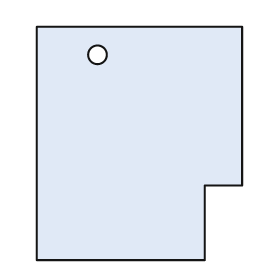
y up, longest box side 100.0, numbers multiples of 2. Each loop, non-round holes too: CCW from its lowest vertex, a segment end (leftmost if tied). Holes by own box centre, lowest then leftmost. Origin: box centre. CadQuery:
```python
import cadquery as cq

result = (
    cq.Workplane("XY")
    .moveTo(-44.0, -50.0)
    .lineTo(28.0, -50.0)
    .lineTo(28.0, -18.0)
    .lineTo(44.0, -18.0)
    .lineTo(44.0, 50.0)
    .lineTo(-44.0, 50.0)
    .close()
    .moveTo(-18.0, 38.0)
    .circle(4.0)
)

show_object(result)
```